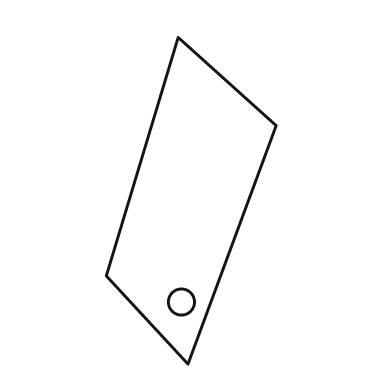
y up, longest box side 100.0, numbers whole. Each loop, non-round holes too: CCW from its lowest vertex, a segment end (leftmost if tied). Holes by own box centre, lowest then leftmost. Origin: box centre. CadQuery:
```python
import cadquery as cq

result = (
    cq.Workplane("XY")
    .moveTo(-1.0, -50.0)
    .lineTo(26.0, 23.0)
    .lineTo(-4.0, 50.0)
    .lineTo(-26.0, -23.0)
    .close()
    .moveTo(-3.0, -31.0)
    .circle(4.0)
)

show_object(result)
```